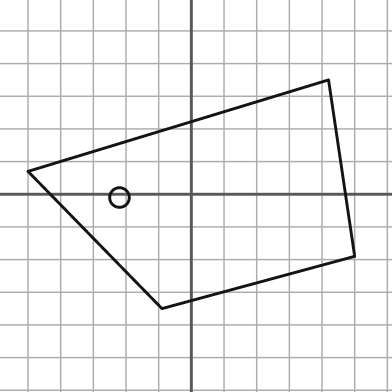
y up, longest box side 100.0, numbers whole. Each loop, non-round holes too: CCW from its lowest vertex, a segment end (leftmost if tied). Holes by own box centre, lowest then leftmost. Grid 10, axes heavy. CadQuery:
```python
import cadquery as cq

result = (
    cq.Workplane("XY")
    .moveTo(-9.0, -35.0)
    .lineTo(50.0, -19.0)
    .lineTo(42.0, 35.0)
    .lineTo(-50.0, 7.0)
    .close()
    .moveTo(-22.0, -1.0)
    .circle(3.0)
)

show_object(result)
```